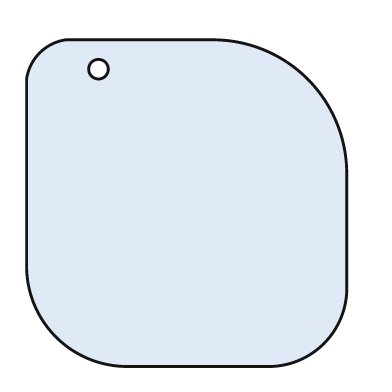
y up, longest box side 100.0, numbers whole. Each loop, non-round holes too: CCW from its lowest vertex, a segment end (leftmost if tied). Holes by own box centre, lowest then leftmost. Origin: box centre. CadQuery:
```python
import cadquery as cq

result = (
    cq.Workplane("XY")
    .moveTo(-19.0, -50.0)
    .lineTo(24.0, -50.0)
    .threePointArc((42.0, -43.0), (49.0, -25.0))
    .lineTo(49.0, 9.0)
    .threePointArc((37.0, 38.0), (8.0, 50.0))
    .lineTo(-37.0, 50.0)
    .threePointArc((-45.0, 46.0), (-49.0, 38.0))
    .lineTo(-49.0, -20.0)
    .threePointArc((-40.0, -41.0), (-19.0, -50.0))
    .close()
    .moveTo(-27.0, 41.0)
    .circle(3.0)
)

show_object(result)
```